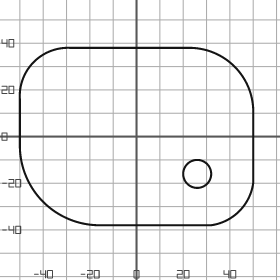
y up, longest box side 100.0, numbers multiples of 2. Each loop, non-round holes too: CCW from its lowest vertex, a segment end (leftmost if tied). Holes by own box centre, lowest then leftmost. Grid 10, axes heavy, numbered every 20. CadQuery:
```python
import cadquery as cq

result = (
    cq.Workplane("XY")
    .moveTo(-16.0, -38.0)
    .lineTo(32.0, -38.0)
    .threePointArc((44.0, -32.0), (50.0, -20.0))
    .lineTo(50.0, 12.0)
    .threePointArc((42.0, 30.0), (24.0, 38.0))
    .lineTo(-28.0, 38.0)
    .threePointArc((-44.0, 32.0), (-50.0, 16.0))
    .lineTo(-50.0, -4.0)
    .threePointArc((-40.0, -28.0), (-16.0, -38.0))
    .close()
    .moveTo(26.0, -16.0)
    .circle(6.0)
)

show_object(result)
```